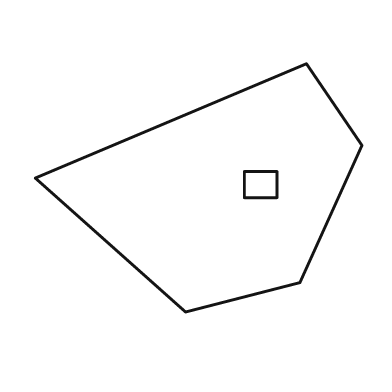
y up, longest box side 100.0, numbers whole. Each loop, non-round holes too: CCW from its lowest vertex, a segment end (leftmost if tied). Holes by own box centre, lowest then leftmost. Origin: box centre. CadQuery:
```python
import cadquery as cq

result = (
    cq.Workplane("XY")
    .moveTo(-4.0, -38.0)
    .lineTo(31.0, -29.0)
    .lineTo(50.0, 13.0)
    .lineTo(33.0, 38.0)
    .lineTo(-50.0, 3.0)
    .close()
    .moveTo(14.0, -3.0)
    .lineTo(24.0, -3.0)
    .lineTo(24.0, 5.0)
    .lineTo(14.0, 5.0)
    .close()
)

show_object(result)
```